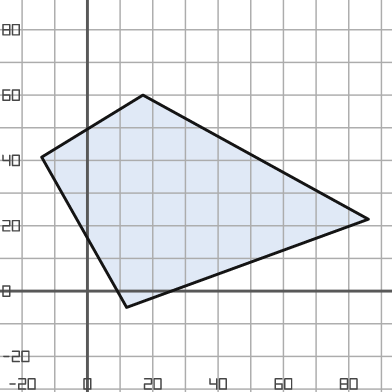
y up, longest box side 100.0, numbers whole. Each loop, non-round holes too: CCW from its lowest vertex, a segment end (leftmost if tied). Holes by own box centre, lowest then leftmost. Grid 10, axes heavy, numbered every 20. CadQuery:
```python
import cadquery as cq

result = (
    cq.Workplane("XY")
    .moveTo(12.0, -5.0)
    .lineTo(86.0, 22.0)
    .lineTo(17.0, 60.0)
    .lineTo(-14.0, 41.0)
    .close()
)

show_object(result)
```